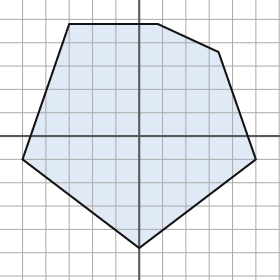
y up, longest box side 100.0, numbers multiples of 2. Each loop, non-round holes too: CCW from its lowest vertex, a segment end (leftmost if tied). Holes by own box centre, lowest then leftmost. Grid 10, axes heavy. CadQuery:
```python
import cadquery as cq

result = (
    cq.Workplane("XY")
    .moveTo(0.0, -48.0)
    .lineTo(50.0, -10.0)
    .lineTo(34.0, 36.0)
    .lineTo(8.0, 48.0)
    .lineTo(-30.0, 48.0)
    .lineTo(-50.0, -10.0)
    .close()
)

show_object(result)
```